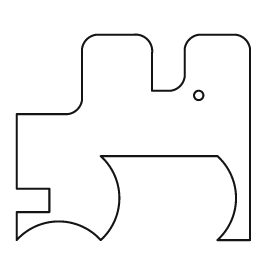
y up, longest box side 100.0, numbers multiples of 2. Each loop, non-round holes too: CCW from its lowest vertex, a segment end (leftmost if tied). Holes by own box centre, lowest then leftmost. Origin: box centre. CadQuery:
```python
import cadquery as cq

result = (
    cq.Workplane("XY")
    .moveTo(-50.0, -44.0)
    .threePointArc((-32.0, -36.0), (-14.0, -44.0))
    .threePointArc((-6.0, -26.0), (-14.0, -8.0))
    .lineTo(36.0, -8.0)
    .threePointArc((44.0, -26.0), (36.0, -44.0))
    .lineTo(50.0, -44.0)
    .lineTo(50.0, 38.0)
    .threePointArc((48.0, 42.0), (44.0, 44.0))
    .lineTo(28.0, 44.0)
    .threePointArc((24.0, 42.0), (22.0, 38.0))
    .lineTo(22.0, 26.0)
    .threePointArc((20.0, 22.0), (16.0, 20.0))
    .lineTo(8.0, 20.0)
    .lineTo(8.0, 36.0)
    .threePointArc((6.0, 42.0), (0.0, 44.0))
    .lineTo(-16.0, 44.0)
    .threePointArc((-20.0, 42.0), (-22.0, 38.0))
    .lineTo(-22.0, 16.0)
    .threePointArc((-24.0, 12.0), (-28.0, 10.0))
    .lineTo(-50.0, 10.0)
    .lineTo(-50.0, -22.0)
    .lineTo(-36.0, -22.0)
    .lineTo(-36.0, -32.0)
    .lineTo(-50.0, -32.0)
    .close()
    .moveTo(28.0, 18.0)
    .circle(2.0)
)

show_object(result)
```